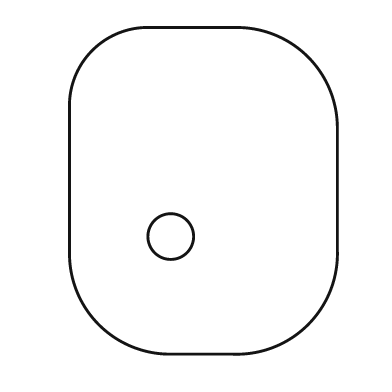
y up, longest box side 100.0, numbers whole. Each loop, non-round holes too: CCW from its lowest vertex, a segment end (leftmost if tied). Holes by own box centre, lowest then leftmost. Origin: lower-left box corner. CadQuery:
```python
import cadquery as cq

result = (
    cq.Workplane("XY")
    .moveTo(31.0, 0.0)
    .lineTo(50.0, 0.0)
    .threePointArc((73.0, 9.0), (82.0, 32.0))
    .lineTo(82.0, 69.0)
    .threePointArc((73.0, 91.0), (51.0, 100.0))
    .lineTo(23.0, 100.0)
    .threePointArc((7.0, 93.0), (0.0, 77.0))
    .lineTo(0.0, 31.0)
    .threePointArc((9.0, 9.0), (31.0, 0.0))
    .close()
    .moveTo(31.0, 36.0)
    .circle(7.0)
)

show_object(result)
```